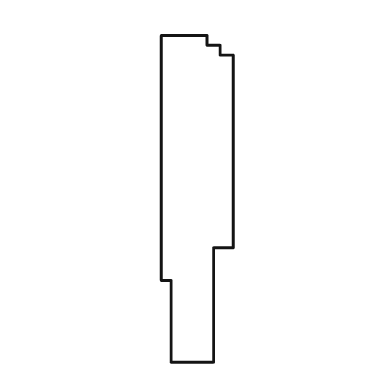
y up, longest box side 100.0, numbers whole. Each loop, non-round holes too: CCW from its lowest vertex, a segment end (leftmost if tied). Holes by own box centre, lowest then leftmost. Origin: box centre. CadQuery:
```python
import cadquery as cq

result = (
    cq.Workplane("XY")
    .moveTo(-8.0, -50.0)
    .lineTo(5.0, -50.0)
    .lineTo(5.0, -15.0)
    .lineTo(11.0, -15.0)
    .lineTo(11.0, 44.0)
    .lineTo(7.0, 44.0)
    .lineTo(7.0, 47.0)
    .lineTo(3.0, 47.0)
    .lineTo(3.0, 50.0)
    .lineTo(-11.0, 50.0)
    .lineTo(-11.0, -25.0)
    .lineTo(-8.0, -25.0)
    .close()
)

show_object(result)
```